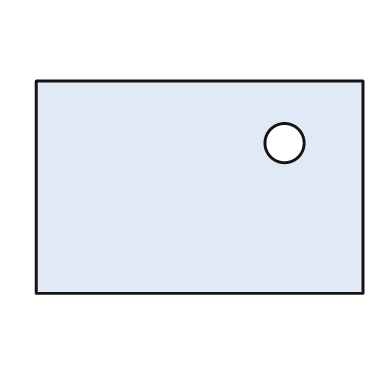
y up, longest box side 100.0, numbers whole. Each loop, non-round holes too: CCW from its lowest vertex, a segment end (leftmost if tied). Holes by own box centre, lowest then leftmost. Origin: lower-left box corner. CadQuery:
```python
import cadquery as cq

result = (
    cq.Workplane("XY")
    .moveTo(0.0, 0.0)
    .lineTo(100.0, 0.0)
    .lineTo(100.0, 65.0)
    .lineTo(0.0, 65.0)
    .close()
    .moveTo(76.0, 46.0)
    .circle(6.0)
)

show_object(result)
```